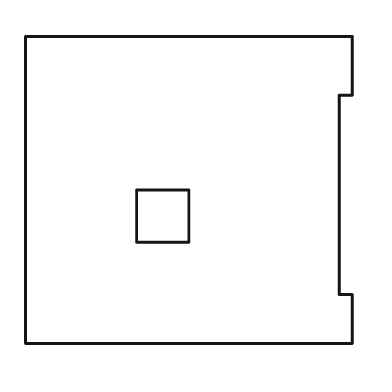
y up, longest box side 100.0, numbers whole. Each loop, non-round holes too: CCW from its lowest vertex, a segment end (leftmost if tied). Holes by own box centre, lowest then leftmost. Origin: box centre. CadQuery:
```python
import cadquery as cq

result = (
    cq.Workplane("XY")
    .moveTo(-50.0, -47.0)
    .lineTo(50.0, -47.0)
    .lineTo(50.0, -32.0)
    .lineTo(46.0, -32.0)
    .lineTo(46.0, 29.0)
    .lineTo(50.0, 29.0)
    .lineTo(50.0, 47.0)
    .lineTo(-50.0, 47.0)
    .close()
    .moveTo(-16.0, -16.0)
    .lineTo(0.0, -16.0)
    .lineTo(0.0, 0.0)
    .lineTo(-16.0, 0.0)
    .close()
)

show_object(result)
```